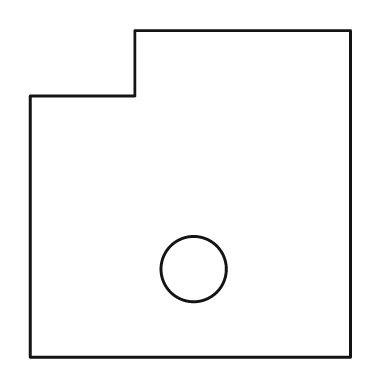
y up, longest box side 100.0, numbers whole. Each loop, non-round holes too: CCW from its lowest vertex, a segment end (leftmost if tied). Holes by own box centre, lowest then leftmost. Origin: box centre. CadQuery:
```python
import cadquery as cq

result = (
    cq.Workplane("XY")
    .moveTo(-49.0, -50.0)
    .lineTo(49.0, -50.0)
    .lineTo(49.0, 50.0)
    .lineTo(-17.0, 50.0)
    .lineTo(-17.0, 30.0)
    .lineTo(-49.0, 30.0)
    .close()
    .moveTo(1.0, -23.0)
    .circle(10.0)
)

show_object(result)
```